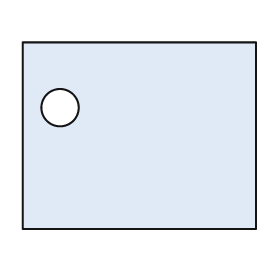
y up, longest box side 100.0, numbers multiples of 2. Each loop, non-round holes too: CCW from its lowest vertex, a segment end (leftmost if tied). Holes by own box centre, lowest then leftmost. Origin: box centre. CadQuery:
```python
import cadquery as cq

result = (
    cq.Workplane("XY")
    .moveTo(-50.0, -40.0)
    .lineTo(50.0, -40.0)
    .lineTo(50.0, 40.0)
    .lineTo(-50.0, 40.0)
    .close()
    .moveTo(-34.0, 12.0)
    .circle(8.0)
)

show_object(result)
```